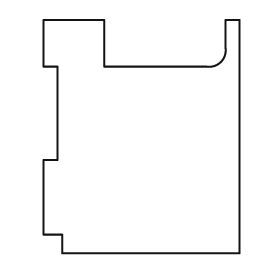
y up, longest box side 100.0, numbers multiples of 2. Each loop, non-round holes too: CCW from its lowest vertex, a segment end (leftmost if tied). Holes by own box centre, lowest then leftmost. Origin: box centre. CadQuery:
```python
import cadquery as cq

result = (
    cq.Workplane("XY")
    .moveTo(-34.0, -50.0)
    .lineTo(42.0, -50.0)
    .lineTo(42.0, 50.0)
    .lineTo(36.0, 50.0)
    .lineTo(36.0, 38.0)
    .threePointArc((34.0, 32.0), (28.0, 30.0))
    .lineTo(-16.0, 30.0)
    .lineTo(-16.0, 50.0)
    .lineTo(-42.0, 50.0)
    .lineTo(-42.0, 30.0)
    .lineTo(-36.0, 30.0)
    .lineTo(-36.0, -10.0)
    .lineTo(-42.0, -10.0)
    .lineTo(-42.0, -42.0)
    .lineTo(-34.0, -42.0)
    .close()
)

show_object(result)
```